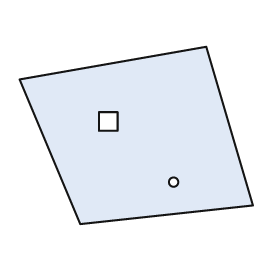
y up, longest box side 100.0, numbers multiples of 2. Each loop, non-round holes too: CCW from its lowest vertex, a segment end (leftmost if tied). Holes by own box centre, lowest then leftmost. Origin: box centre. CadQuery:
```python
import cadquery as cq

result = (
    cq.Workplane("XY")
    .moveTo(-24.0, -38.0)
    .lineTo(50.0, -30.0)
    .lineTo(30.0, 38.0)
    .lineTo(-50.0, 24.0)
    .close()
    .moveTo(16.0, -20.0)
    .circle(2.0)
    .moveTo(-16.0, 2.0)
    .lineTo(-8.0, 2.0)
    .lineTo(-8.0, 10.0)
    .lineTo(-16.0, 10.0)
    .close()
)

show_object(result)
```